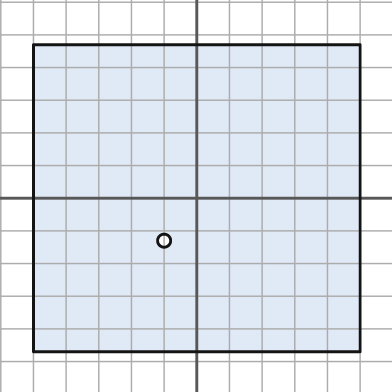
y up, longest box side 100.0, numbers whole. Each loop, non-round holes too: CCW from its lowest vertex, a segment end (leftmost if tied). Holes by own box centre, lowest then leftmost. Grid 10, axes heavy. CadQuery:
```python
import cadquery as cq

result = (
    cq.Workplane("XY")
    .moveTo(-50.0, -47.0)
    .lineTo(50.0, -47.0)
    .lineTo(50.0, 47.0)
    .lineTo(-50.0, 47.0)
    .close()
    .moveTo(-10.0, -13.0)
    .circle(2.0)
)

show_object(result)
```